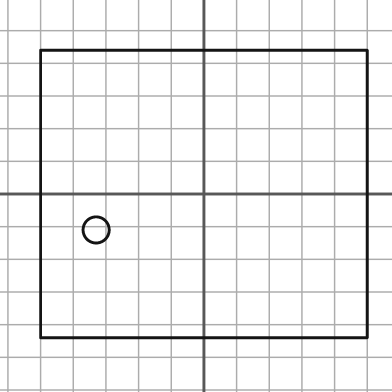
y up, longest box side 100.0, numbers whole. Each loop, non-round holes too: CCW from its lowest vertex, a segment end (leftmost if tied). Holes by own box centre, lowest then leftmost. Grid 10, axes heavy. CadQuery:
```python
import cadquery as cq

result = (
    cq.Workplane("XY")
    .moveTo(-50.0, -44.0)
    .lineTo(50.0, -44.0)
    .lineTo(50.0, 44.0)
    .lineTo(-50.0, 44.0)
    .close()
    .moveTo(-33.0, -11.0)
    .circle(4.0)
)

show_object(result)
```